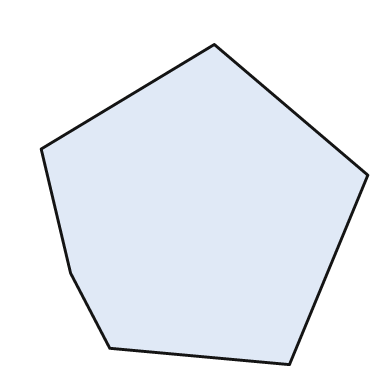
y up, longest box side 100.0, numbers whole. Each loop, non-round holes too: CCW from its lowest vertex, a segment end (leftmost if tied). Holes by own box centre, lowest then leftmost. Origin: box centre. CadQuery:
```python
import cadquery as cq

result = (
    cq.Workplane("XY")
    .moveTo(26.0, -49.0)
    .lineTo(50.0, 9.0)
    .lineTo(3.0, 49.0)
    .lineTo(-50.0, 17.0)
    .lineTo(-41.0, -21.0)
    .lineTo(-29.0, -44.0)
    .close()
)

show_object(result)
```